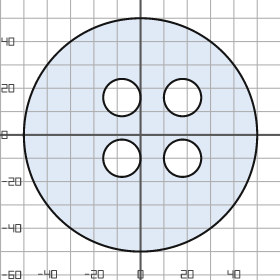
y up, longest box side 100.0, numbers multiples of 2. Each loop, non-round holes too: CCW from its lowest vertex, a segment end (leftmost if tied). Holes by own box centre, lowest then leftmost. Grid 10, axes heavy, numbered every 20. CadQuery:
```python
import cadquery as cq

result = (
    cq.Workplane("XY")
    .moveTo(0.0, 0.0)
    .circle(50.0)
    .moveTo(-8.0, -10.0)
    .circle(8.0)
    .moveTo(18.0, -10.0)
    .circle(8.0)
    .moveTo(-8.0, 16.0)
    .circle(8.0)
    .moveTo(18.0, 16.0)
    .circle(8.0)
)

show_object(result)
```